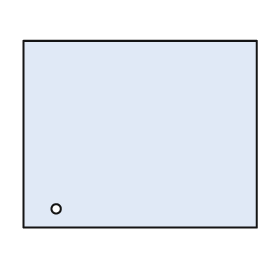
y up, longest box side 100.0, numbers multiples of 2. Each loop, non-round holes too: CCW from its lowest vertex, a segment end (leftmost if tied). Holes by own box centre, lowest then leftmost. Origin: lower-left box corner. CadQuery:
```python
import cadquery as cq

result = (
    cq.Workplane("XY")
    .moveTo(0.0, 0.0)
    .lineTo(100.0, 0.0)
    .lineTo(100.0, 80.0)
    .lineTo(0.0, 80.0)
    .close()
    .moveTo(14.0, 8.0)
    .circle(2.0)
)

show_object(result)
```